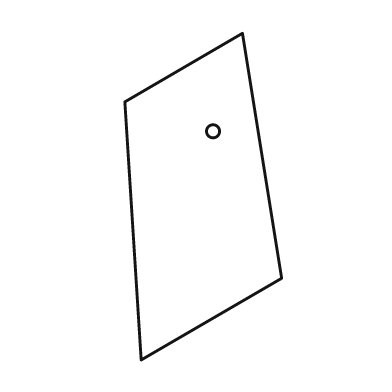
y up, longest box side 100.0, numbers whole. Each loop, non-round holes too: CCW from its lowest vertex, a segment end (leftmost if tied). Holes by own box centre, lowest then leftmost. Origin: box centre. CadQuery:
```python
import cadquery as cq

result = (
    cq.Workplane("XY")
    .moveTo(-19.0, -50.0)
    .lineTo(24.0, -25.0)
    .lineTo(12.0, 50.0)
    .lineTo(-24.0, 29.0)
    .close()
    .moveTo(3.0, 20.0)
    .circle(2.0)
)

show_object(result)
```